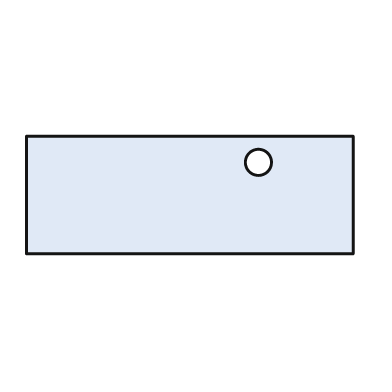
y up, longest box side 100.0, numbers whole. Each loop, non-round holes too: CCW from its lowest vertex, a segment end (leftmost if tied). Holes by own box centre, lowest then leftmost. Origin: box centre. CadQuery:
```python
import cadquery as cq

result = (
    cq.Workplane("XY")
    .moveTo(-50.0, -18.0)
    .lineTo(50.0, -18.0)
    .lineTo(50.0, 18.0)
    .lineTo(-50.0, 18.0)
    .close()
    .moveTo(21.0, 10.0)
    .circle(4.0)
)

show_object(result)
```